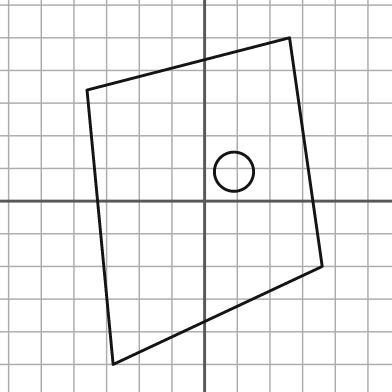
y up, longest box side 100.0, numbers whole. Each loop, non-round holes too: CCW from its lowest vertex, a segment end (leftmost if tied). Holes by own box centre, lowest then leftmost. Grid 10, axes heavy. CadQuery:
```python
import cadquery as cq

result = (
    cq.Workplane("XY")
    .moveTo(-28.0, -50.0)
    .lineTo(36.0, -20.0)
    .lineTo(26.0, 50.0)
    .lineTo(-36.0, 34.0)
    .close()
    .moveTo(9.0, 9.0)
    .circle(6.0)
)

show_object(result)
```